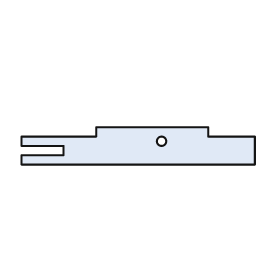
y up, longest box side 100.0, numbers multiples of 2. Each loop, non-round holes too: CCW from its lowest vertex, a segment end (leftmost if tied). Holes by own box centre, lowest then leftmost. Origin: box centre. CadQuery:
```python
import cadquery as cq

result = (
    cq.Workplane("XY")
    .moveTo(-50.0, -8.0)
    .lineTo(50.0, -8.0)
    .lineTo(50.0, 4.0)
    .lineTo(30.0, 4.0)
    .lineTo(30.0, 8.0)
    .lineTo(-18.0, 8.0)
    .lineTo(-18.0, 4.0)
    .lineTo(-50.0, 4.0)
    .lineTo(-50.0, 0.0)
    .lineTo(-32.0, 0.0)
    .lineTo(-32.0, -4.0)
    .lineTo(-50.0, -4.0)
    .close()
    .moveTo(10.0, 2.0)
    .circle(2.0)
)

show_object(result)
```